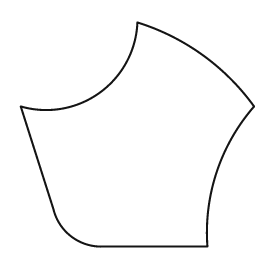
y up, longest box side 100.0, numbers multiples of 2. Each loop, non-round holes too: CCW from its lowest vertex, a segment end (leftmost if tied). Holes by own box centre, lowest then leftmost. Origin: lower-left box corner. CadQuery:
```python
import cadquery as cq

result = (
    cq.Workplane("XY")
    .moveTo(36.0, 0.0)
    .lineTo(80.0, 0.0)
    .threePointArc((84.0, 32.0), (100.0, 60.0))
    .threePointArc((78.0, 82.0), (50.0, 96.0))
    .threePointArc((34.0, 66.0), (0.0, 60.0))
    .lineTo(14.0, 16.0)
    .threePointArc((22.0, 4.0), (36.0, 0.0))
    .close()
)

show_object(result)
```